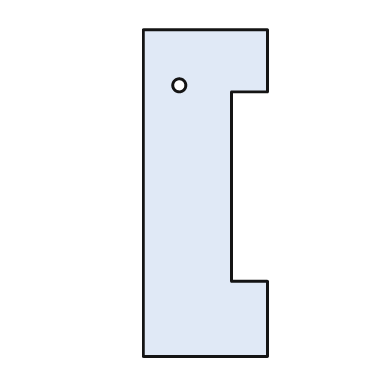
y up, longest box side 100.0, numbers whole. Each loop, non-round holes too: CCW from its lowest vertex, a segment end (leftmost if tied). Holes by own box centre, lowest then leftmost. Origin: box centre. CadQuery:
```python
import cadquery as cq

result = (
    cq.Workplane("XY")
    .moveTo(-19.0, -50.0)
    .lineTo(19.0, -50.0)
    .lineTo(19.0, -27.0)
    .lineTo(8.0, -27.0)
    .lineTo(8.0, 31.0)
    .lineTo(19.0, 31.0)
    .lineTo(19.0, 50.0)
    .lineTo(-19.0, 50.0)
    .close()
    .moveTo(-8.0, 33.0)
    .circle(2.0)
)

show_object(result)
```